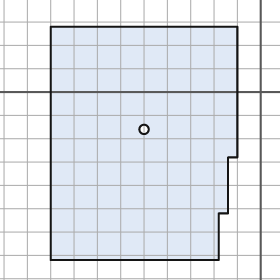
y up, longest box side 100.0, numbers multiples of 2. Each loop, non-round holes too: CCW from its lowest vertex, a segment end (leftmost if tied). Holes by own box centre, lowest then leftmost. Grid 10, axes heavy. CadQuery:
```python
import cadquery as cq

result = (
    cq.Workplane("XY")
    .moveTo(-90.0, -72.0)
    .lineTo(-18.0, -72.0)
    .lineTo(-18.0, -52.0)
    .lineTo(-14.0, -52.0)
    .lineTo(-14.0, -28.0)
    .lineTo(-10.0, -28.0)
    .lineTo(-10.0, 28.0)
    .lineTo(-90.0, 28.0)
    .close()
    .moveTo(-50.0, -16.0)
    .circle(2.0)
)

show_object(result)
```